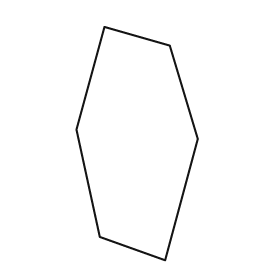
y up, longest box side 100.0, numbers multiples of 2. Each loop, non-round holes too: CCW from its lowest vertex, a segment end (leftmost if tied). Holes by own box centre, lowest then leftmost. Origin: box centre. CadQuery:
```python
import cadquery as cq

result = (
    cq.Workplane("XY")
    .moveTo(12.0, -50.0)
    .lineTo(26.0, 2.0)
    .lineTo(14.0, 42.0)
    .lineTo(-14.0, 50.0)
    .lineTo(-26.0, 6.0)
    .lineTo(-16.0, -40.0)
    .close()
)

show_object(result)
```